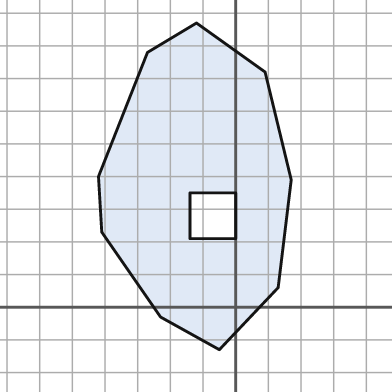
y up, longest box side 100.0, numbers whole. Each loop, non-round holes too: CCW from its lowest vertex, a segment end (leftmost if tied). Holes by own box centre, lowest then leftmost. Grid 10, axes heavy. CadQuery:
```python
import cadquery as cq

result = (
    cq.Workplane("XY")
    .moveTo(-5.0, -13.0)
    .lineTo(13.0, 6.0)
    .lineTo(17.0, 39.0)
    .lineTo(9.0, 72.0)
    .lineTo(-12.0, 87.0)
    .lineTo(-27.0, 78.0)
    .lineTo(-42.0, 40.0)
    .lineTo(-41.0, 23.0)
    .lineTo(-23.0, -3.0)
    .close()
    .moveTo(-14.0, 21.0)
    .lineTo(0.0, 21.0)
    .lineTo(0.0, 35.0)
    .lineTo(-14.0, 35.0)
    .close()
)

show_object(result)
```